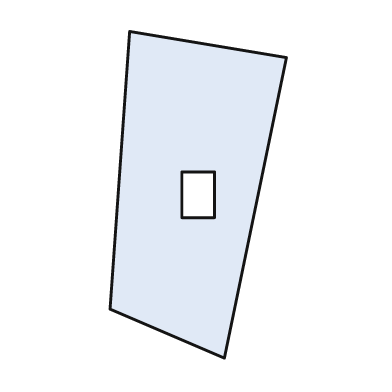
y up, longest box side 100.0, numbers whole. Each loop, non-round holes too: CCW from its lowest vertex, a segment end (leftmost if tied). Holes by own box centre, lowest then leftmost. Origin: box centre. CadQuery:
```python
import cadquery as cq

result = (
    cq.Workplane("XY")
    .moveTo(8.0, -50.0)
    .lineTo(27.0, 42.0)
    .lineTo(-21.0, 50.0)
    .lineTo(-27.0, -35.0)
    .close()
    .moveTo(-5.0, -7.0)
    .lineTo(5.0, -7.0)
    .lineTo(5.0, 7.0)
    .lineTo(-5.0, 7.0)
    .close()
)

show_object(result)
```